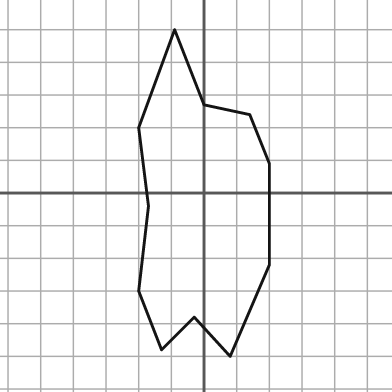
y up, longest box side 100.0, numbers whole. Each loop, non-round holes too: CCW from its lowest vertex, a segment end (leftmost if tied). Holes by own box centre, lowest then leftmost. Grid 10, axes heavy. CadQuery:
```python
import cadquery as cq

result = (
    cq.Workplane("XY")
    .moveTo(8.0, -50.0)
    .lineTo(20.0, -22.0)
    .lineTo(20.0, 9.0)
    .lineTo(14.0, 24.0)
    .lineTo(0.0, 27.0)
    .lineTo(-9.0, 50.0)
    .lineTo(-20.0, 20.0)
    .lineTo(-17.0, -4.0)
    .lineTo(-20.0, -30.0)
    .lineTo(-13.0, -48.0)
    .lineTo(-3.0, -38.0)
    .close()
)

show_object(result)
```